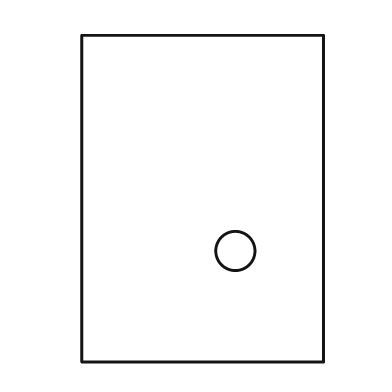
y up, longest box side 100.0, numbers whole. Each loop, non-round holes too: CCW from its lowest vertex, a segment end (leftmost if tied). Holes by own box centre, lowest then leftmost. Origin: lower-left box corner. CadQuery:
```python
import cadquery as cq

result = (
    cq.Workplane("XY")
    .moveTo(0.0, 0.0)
    .lineTo(74.0, 0.0)
    .lineTo(74.0, 100.0)
    .lineTo(0.0, 100.0)
    .close()
    .moveTo(47.0, 34.0)
    .circle(6.0)
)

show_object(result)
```